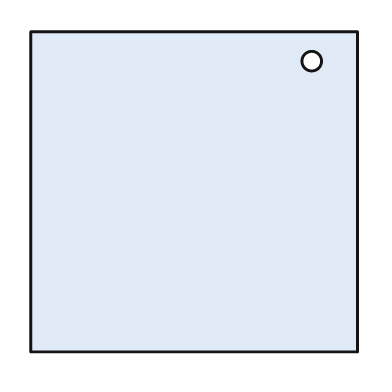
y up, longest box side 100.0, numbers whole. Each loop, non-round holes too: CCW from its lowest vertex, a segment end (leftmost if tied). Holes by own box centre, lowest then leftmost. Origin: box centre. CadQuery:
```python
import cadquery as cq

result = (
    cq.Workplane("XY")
    .moveTo(-50.0, -49.0)
    .lineTo(50.0, -49.0)
    .lineTo(50.0, 49.0)
    .lineTo(-50.0, 49.0)
    .close()
    .moveTo(36.0, 40.0)
    .circle(3.0)
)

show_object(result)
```